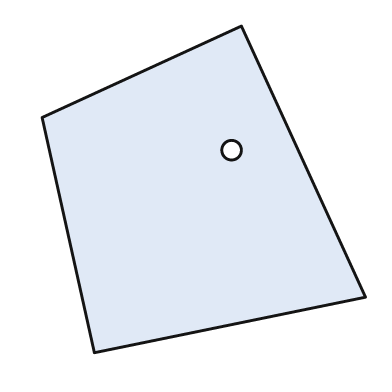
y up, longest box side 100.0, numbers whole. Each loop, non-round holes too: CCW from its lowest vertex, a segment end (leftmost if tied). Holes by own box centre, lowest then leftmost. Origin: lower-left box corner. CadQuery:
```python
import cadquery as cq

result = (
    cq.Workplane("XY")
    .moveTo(16.0, 0.0)
    .lineTo(99.0, 17.0)
    .lineTo(61.0, 100.0)
    .lineTo(0.0, 72.0)
    .close()
    .moveTo(58.0, 62.0)
    .circle(3.0)
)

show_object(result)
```